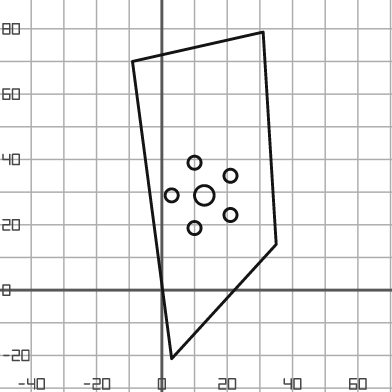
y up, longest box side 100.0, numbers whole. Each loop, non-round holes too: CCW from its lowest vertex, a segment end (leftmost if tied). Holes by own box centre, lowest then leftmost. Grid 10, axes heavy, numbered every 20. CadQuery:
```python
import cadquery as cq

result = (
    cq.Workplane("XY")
    .moveTo(3.0, -21.0)
    .lineTo(35.0, 14.0)
    .lineTo(31.0, 79.0)
    .lineTo(-9.0, 70.0)
    .close()
    .moveTo(10.0, 19.0)
    .circle(2.0)
    .moveTo(21.0, 23.0)
    .circle(2.0)
    .moveTo(3.0, 29.0)
    .circle(2.0)
    .moveTo(13.0, 29.0)
    .circle(3.0)
    .moveTo(21.0, 35.0)
    .circle(2.0)
    .moveTo(10.0, 39.0)
    .circle(2.0)
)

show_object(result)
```